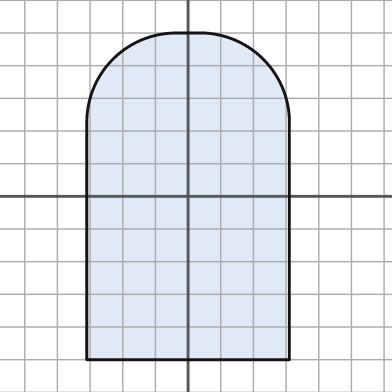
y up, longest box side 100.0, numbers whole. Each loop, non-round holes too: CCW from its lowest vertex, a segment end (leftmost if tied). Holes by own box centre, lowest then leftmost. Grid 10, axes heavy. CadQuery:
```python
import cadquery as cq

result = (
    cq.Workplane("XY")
    .moveTo(-31.0, -50.0)
    .lineTo(31.0, -50.0)
    .lineTo(31.0, 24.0)
    .threePointArc((23.0, 42.0), (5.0, 50.0))
    .lineTo(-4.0, 50.0)
    .threePointArc((-23.0, 42.0), (-31.0, 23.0))
    .close()
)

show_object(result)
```